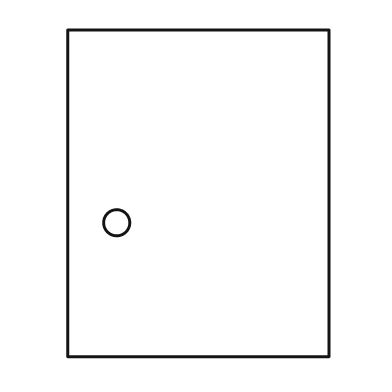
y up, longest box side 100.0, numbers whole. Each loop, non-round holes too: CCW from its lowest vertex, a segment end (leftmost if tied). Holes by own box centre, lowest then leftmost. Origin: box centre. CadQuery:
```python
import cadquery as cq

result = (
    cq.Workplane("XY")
    .moveTo(-40.0, -50.0)
    .lineTo(40.0, -50.0)
    .lineTo(40.0, 50.0)
    .lineTo(-40.0, 50.0)
    .close()
    .moveTo(-25.0, -9.0)
    .circle(4.0)
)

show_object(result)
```